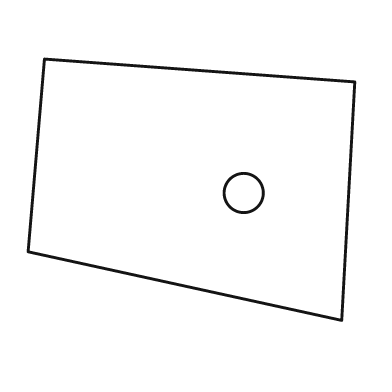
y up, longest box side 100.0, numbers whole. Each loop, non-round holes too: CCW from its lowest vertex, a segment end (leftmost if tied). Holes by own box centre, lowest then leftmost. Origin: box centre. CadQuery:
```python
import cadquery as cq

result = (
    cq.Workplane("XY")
    .moveTo(46.0, -40.0)
    .lineTo(50.0, 33.0)
    .lineTo(-45.0, 40.0)
    .lineTo(-50.0, -19.0)
    .close()
    .moveTo(16.0, -1.0)
    .circle(6.0)
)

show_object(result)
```